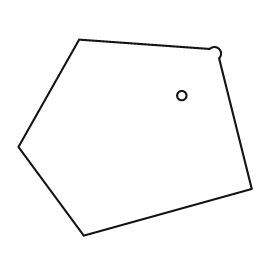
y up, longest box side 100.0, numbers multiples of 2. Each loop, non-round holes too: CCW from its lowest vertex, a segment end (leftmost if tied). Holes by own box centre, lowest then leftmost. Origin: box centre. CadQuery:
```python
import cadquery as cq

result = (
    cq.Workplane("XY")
    .moveTo(-22.0, -42.0)
    .lineTo(50.0, -22.0)
    .lineTo(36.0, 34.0)
    .threePointArc((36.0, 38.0), (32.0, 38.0))
    .lineTo(-24.0, 42.0)
    .lineTo(-50.0, -4.0)
    .close()
    .moveTo(20.0, 18.0)
    .circle(2.0)
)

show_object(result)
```